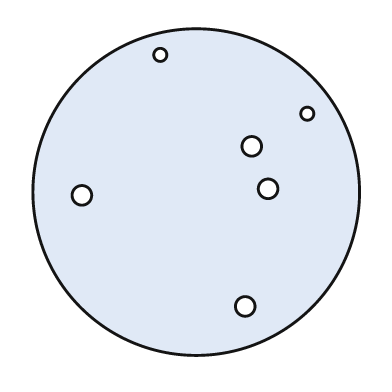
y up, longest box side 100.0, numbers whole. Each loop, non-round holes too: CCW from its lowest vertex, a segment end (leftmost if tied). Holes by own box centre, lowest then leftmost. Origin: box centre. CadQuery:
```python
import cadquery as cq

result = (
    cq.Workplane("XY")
    .moveTo(0.0, 0.0)
    .circle(50.0)
    .moveTo(15.0, -35.0)
    .circle(3.0)
    .moveTo(-35.0, -1.0)
    .circle(3.0)
    .moveTo(22.0, 1.0)
    .circle(3.0)
    .moveTo(17.0, 14.0)
    .circle(3.0)
    .moveTo(34.0, 24.0)
    .circle(2.0)
    .moveTo(-11.0, 42.0)
    .circle(2.0)
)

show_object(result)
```